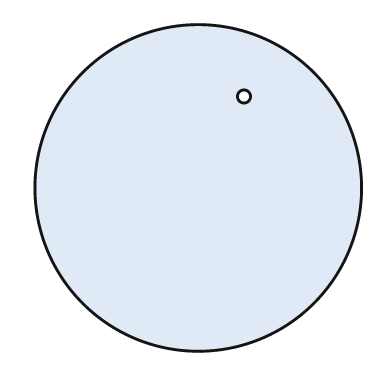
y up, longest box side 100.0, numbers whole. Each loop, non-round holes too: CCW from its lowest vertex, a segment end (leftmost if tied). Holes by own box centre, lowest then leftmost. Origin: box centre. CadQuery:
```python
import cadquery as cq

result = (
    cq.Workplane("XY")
    .moveTo(0.0, 0.0)
    .circle(50.0)
    .moveTo(14.0, 28.0)
    .circle(2.0)
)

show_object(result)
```